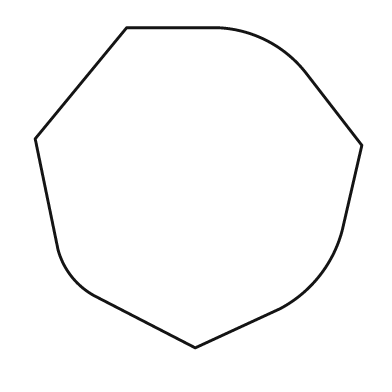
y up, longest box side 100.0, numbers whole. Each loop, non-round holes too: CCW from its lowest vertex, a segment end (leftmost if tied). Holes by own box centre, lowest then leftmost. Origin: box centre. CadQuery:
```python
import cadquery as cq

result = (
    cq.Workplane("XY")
    .moveTo(-1.0, -49.0)
    .lineTo(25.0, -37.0)
    .threePointArc((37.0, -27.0), (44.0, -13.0))
    .lineTo(50.0, 13.0)
    .lineTo(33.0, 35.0)
    .threePointArc((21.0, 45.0), (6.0, 49.0))
    .lineTo(-22.0, 49.0)
    .lineTo(-50.0, 15.0)
    .lineTo(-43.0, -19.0)
    .threePointArc((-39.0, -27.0), (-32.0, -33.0))
    .close()
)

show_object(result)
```